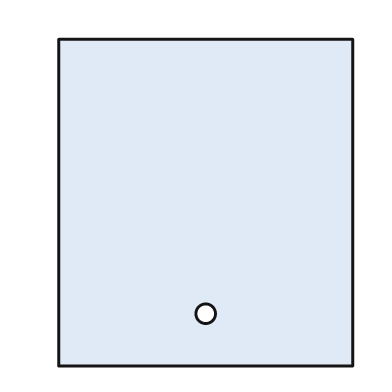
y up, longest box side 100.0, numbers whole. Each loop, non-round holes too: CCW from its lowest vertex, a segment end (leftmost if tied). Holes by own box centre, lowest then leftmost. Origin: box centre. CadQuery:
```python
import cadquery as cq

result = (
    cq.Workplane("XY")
    .moveTo(-45.0, -50.0)
    .lineTo(45.0, -50.0)
    .lineTo(45.0, 50.0)
    .lineTo(-45.0, 50.0)
    .close()
    .moveTo(0.0, -34.0)
    .circle(3.0)
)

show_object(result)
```